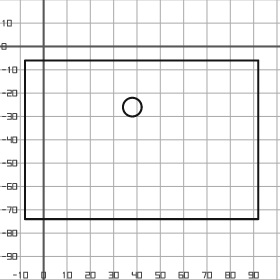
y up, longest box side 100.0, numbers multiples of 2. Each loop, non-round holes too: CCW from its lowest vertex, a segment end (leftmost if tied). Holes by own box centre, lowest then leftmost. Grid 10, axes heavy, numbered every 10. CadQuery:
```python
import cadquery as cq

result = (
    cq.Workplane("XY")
    .moveTo(-8.0, -74.0)
    .lineTo(92.0, -74.0)
    .lineTo(92.0, -6.0)
    .lineTo(-8.0, -6.0)
    .close()
    .moveTo(38.0, -26.0)
    .circle(4.0)
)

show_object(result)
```